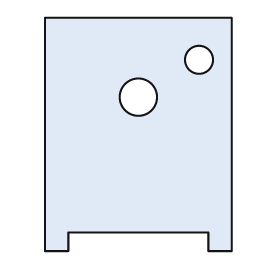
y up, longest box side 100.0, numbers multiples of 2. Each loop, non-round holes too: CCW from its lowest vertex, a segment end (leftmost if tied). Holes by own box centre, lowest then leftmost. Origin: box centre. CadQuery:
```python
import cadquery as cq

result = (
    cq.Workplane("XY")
    .moveTo(-40.0, -50.0)
    .lineTo(-30.0, -50.0)
    .lineTo(-30.0, -42.0)
    .lineTo(30.0, -42.0)
    .lineTo(30.0, -50.0)
    .lineTo(40.0, -50.0)
    .lineTo(40.0, 50.0)
    .lineTo(-40.0, 50.0)
    .close()
    .moveTo(0.0, 16.0)
    .circle(8.0)
    .moveTo(26.0, 32.0)
    .circle(6.0)
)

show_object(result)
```